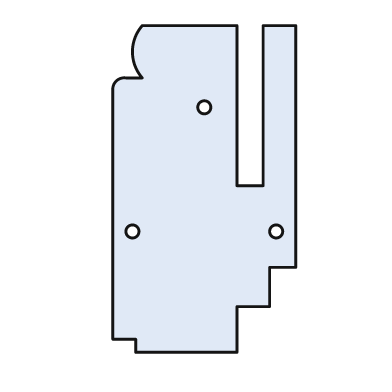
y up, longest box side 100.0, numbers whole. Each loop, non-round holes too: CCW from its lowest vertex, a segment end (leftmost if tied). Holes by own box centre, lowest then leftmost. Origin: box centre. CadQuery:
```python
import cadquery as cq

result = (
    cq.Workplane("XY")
    .moveTo(-21.0, -50.0)
    .lineTo(10.0, -50.0)
    .lineTo(10.0, -36.0)
    .lineTo(20.0, -36.0)
    .lineTo(20.0, -24.0)
    .lineTo(28.0, -24.0)
    .lineTo(28.0, 50.0)
    .lineTo(18.0, 50.0)
    .lineTo(18.0, 1.0)
    .lineTo(10.0, 1.0)
    .lineTo(10.0, 50.0)
    .lineTo(-19.0, 50.0)
    .threePointArc((-22.0, 42.0), (-19.0, 34.0))
    .lineTo(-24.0, 34.0)
    .threePointArc((-27.0, 33.0), (-28.0, 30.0))
    .lineTo(-28.0, -46.0)
    .lineTo(-21.0, -46.0)
    .close()
    .moveTo(-22.0, -13.0)
    .circle(2.0)
    .moveTo(22.0, -13.0)
    .circle(2.0)
    .moveTo(0.0, 25.0)
    .circle(2.0)
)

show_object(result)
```